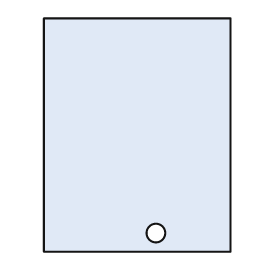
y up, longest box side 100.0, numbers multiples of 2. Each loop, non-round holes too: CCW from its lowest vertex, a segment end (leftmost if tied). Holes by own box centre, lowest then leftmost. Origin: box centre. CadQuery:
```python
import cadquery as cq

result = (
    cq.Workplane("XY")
    .moveTo(-40.0, -50.0)
    .lineTo(40.0, -50.0)
    .lineTo(40.0, 50.0)
    .lineTo(-40.0, 50.0)
    .close()
    .moveTo(8.0, -42.0)
    .circle(4.0)
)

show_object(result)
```